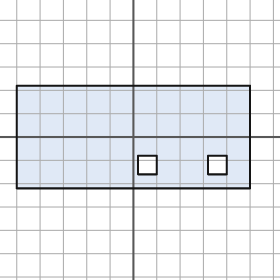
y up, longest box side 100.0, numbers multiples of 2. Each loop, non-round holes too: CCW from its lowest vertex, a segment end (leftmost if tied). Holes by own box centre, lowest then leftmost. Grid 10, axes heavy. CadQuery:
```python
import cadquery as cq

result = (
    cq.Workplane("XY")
    .moveTo(-50.0, -22.0)
    .lineTo(50.0, -22.0)
    .lineTo(50.0, 22.0)
    .lineTo(-50.0, 22.0)
    .close()
    .moveTo(2.0, -16.0)
    .lineTo(10.0, -16.0)
    .lineTo(10.0, -8.0)
    .lineTo(2.0, -8.0)
    .close()
    .moveTo(32.0, -16.0)
    .lineTo(40.0, -16.0)
    .lineTo(40.0, -8.0)
    .lineTo(32.0, -8.0)
    .close()
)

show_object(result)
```